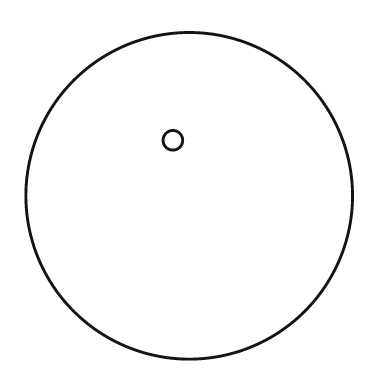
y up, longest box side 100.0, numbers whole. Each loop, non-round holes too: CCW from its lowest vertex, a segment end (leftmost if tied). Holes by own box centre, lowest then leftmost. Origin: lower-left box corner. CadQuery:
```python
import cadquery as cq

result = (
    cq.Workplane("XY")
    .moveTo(50.0, 50.0)
    .circle(50.0)
    .moveTo(45.0, 67.0)
    .circle(3.0)
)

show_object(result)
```